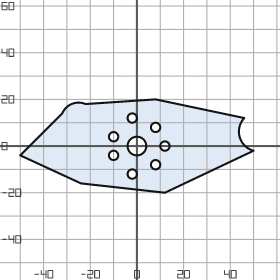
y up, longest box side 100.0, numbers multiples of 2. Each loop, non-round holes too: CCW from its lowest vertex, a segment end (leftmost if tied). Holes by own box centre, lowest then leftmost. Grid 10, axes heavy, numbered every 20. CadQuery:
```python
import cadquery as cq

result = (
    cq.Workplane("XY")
    .moveTo(12.0, -20.0)
    .lineTo(50.0, -2.0)
    .threePointArc((44.0, 4.0), (46.0, 12.0))
    .lineTo(8.0, 20.0)
    .lineTo(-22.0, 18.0)
    .threePointArc((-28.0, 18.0), (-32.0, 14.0))
    .lineTo(-50.0, -4.0)
    .lineTo(-24.0, -16.0)
    .close()
    .moveTo(-2.0, -12.0)
    .circle(2.0)
    .moveTo(8.0, -8.0)
    .circle(2.0)
    .moveTo(-10.0, -4.0)
    .circle(2.0)
    .moveTo(0.0, 0.0)
    .circle(4.0)
    .moveTo(12.0, 0.0)
    .circle(2.0)
    .moveTo(-10.0, 4.0)
    .circle(2.0)
    .moveTo(8.0, 8.0)
    .circle(2.0)
    .moveTo(-2.0, 12.0)
    .circle(2.0)
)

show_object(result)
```